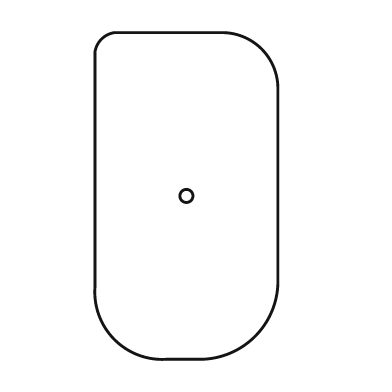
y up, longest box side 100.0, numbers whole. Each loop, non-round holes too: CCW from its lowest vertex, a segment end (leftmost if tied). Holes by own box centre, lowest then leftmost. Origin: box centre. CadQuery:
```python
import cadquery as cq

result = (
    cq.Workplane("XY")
    .moveTo(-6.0, -50.0)
    .lineTo(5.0, -50.0)
    .threePointArc((21.0, -43.0), (28.0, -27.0))
    .lineTo(28.0, 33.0)
    .threePointArc((23.0, 45.0), (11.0, 50.0))
    .lineTo(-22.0, 50.0)
    .threePointArc((-26.0, 48.0), (-28.0, 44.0))
    .lineTo(-28.0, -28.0)
    .threePointArc((-22.0, -44.0), (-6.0, -50.0))
    .close()
    .moveTo(0.0, 0.0)
    .circle(2.0)
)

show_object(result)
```